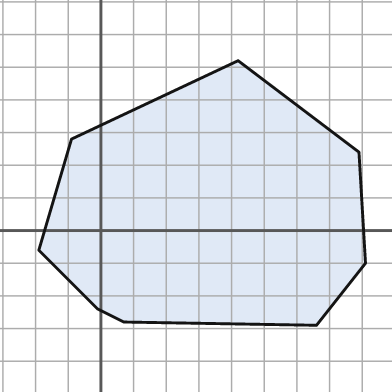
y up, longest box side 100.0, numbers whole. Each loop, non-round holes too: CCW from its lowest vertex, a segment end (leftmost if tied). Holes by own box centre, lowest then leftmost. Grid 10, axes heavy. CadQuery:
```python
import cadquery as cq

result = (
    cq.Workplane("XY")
    .moveTo(66.0, -29.0)
    .lineTo(81.0, -10.0)
    .lineTo(79.0, 24.0)
    .lineTo(42.0, 52.0)
    .lineTo(-9.0, 28.0)
    .lineTo(-19.0, -6.0)
    .lineTo(-1.0, -24.0)
    .lineTo(7.0, -28.0)
    .close()
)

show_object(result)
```